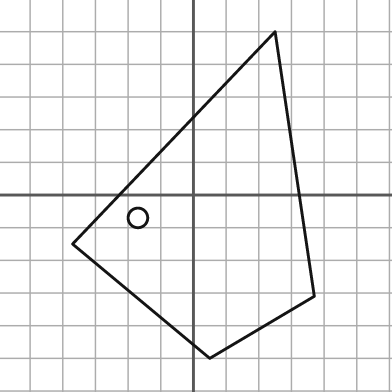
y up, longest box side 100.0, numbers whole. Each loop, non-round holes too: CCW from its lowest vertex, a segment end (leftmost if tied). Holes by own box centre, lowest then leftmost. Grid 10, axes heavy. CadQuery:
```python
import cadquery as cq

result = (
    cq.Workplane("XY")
    .moveTo(5.0, -50.0)
    .lineTo(37.0, -31.0)
    .lineTo(25.0, 50.0)
    .lineTo(-37.0, -15.0)
    .close()
    .moveTo(-17.0, -7.0)
    .circle(3.0)
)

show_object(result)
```